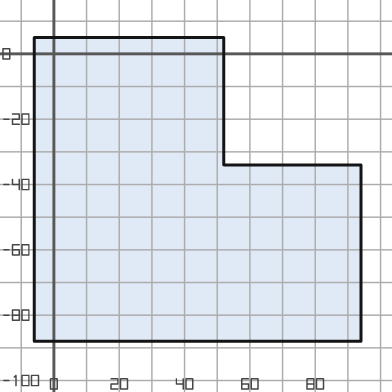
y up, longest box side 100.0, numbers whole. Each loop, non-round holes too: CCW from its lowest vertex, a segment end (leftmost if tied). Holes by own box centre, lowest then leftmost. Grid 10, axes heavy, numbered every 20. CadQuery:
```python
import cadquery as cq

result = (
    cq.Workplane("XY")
    .moveTo(-6.0, -88.0)
    .lineTo(94.0, -88.0)
    .lineTo(94.0, -34.0)
    .lineTo(52.0, -34.0)
    .lineTo(52.0, 5.0)
    .lineTo(-6.0, 5.0)
    .close()
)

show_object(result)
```